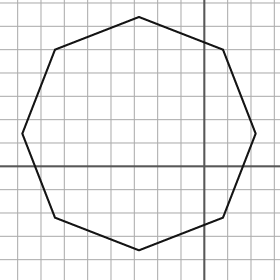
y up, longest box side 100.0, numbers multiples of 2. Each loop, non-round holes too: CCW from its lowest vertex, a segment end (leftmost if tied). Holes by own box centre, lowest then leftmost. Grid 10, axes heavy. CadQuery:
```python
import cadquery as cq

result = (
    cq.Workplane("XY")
    .moveTo(-28.0, -36.0)
    .lineTo(8.0, -22.0)
    .lineTo(22.0, 14.0)
    .lineTo(8.0, 50.0)
    .lineTo(-28.0, 64.0)
    .lineTo(-64.0, 50.0)
    .lineTo(-78.0, 14.0)
    .lineTo(-64.0, -22.0)
    .close()
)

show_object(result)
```